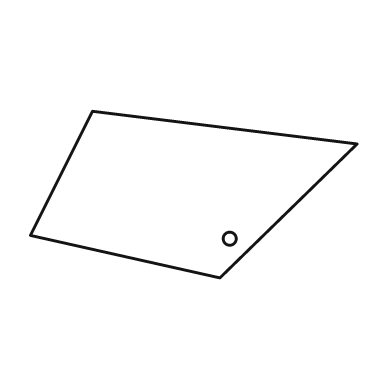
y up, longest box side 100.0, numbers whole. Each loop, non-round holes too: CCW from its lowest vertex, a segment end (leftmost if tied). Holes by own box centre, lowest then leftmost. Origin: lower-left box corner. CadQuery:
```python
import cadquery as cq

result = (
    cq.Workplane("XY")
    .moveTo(58.0, 0.0)
    .lineTo(100.0, 41.0)
    .lineTo(19.0, 51.0)
    .lineTo(0.0, 13.0)
    .close()
    .moveTo(61.0, 12.0)
    .circle(2.0)
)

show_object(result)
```